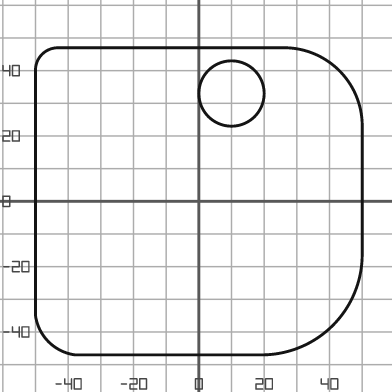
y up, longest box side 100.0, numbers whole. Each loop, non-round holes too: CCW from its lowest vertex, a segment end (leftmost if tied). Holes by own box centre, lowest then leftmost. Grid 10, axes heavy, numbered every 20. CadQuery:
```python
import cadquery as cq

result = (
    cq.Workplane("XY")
    .moveTo(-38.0, -47.0)
    .lineTo(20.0, -47.0)
    .threePointArc((41.0, -38.0), (50.0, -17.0))
    .lineTo(50.0, 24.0)
    .threePointArc((43.0, 40.0), (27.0, 47.0))
    .lineTo(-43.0, 47.0)
    .threePointArc((-48.0, 45.0), (-50.0, 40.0))
    .lineTo(-50.0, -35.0)
    .threePointArc((-46.0, -43.0), (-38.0, -47.0))
    .close()
    .moveTo(10.0, 33.0)
    .circle(10.0)
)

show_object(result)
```